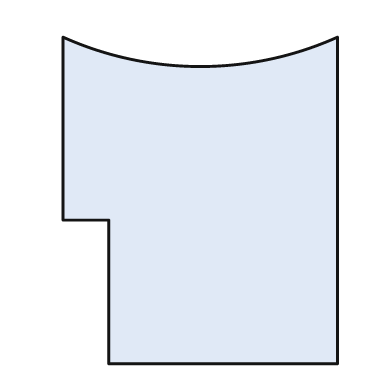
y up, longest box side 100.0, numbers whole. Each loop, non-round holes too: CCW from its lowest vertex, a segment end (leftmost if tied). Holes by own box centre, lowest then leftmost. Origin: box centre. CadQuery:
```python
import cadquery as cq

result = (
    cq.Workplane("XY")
    .moveTo(-28.0, -50.0)
    .lineTo(42.0, -50.0)
    .lineTo(42.0, 50.0)
    .threePointArc((0.0, 41.0), (-42.0, 50.0))
    .lineTo(-42.0, -6.0)
    .lineTo(-28.0, -6.0)
    .close()
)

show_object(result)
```